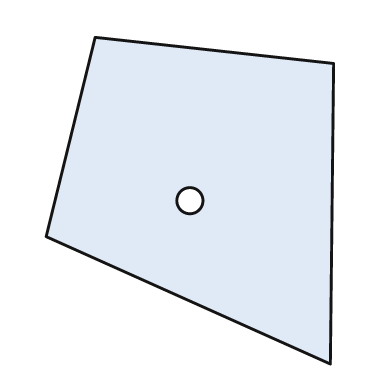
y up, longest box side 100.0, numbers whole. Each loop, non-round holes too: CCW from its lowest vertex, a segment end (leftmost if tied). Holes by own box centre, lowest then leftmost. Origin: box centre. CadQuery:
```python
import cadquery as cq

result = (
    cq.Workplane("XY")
    .moveTo(43.0, -50.0)
    .lineTo(44.0, 42.0)
    .lineTo(-29.0, 50.0)
    .lineTo(-44.0, -11.0)
    .close()
    .moveTo(0.0, 0.0)
    .circle(4.0)
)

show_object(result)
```